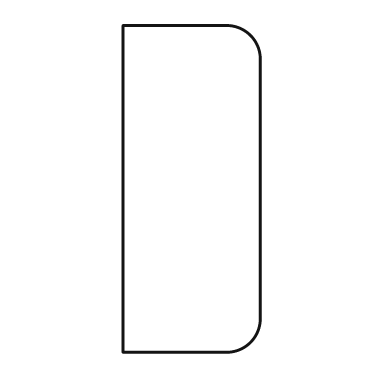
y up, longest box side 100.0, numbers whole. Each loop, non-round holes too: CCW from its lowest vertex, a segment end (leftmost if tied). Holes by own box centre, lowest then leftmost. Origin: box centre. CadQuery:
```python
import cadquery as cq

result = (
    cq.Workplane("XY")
    .moveTo(-21.0, -50.0)
    .lineTo(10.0, -50.0)
    .threePointArc((18.0, -47.0), (21.0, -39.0))
    .lineTo(21.0, 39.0)
    .threePointArc((18.0, 47.0), (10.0, 50.0))
    .lineTo(-21.0, 50.0)
    .close()
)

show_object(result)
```